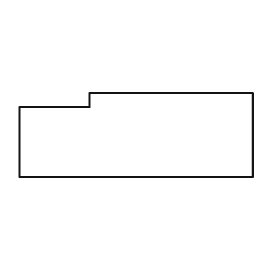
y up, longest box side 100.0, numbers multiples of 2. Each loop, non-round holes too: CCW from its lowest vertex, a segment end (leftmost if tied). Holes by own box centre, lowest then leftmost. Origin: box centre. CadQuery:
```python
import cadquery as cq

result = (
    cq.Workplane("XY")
    .moveTo(-50.0, -18.0)
    .lineTo(50.0, -18.0)
    .lineTo(50.0, 18.0)
    .lineTo(-20.0, 18.0)
    .lineTo(-20.0, 12.0)
    .lineTo(-50.0, 12.0)
    .close()
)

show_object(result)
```